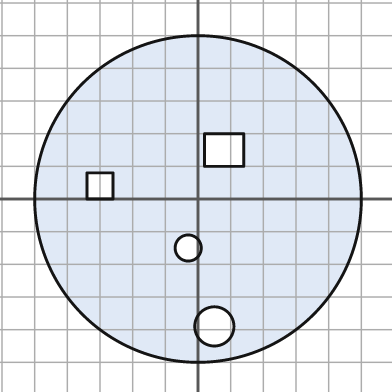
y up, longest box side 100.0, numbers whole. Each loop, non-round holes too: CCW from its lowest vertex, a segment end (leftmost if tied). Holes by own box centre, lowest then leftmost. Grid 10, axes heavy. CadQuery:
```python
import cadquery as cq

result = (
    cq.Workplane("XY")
    .moveTo(0.0, 0.0)
    .circle(50.0)
    .moveTo(5.0, -39.0)
    .circle(6.0)
    .moveTo(-3.0, -15.0)
    .circle(4.0)
    .moveTo(-34.0, 0.0)
    .lineTo(-26.0, 0.0)
    .lineTo(-26.0, 8.0)
    .lineTo(-34.0, 8.0)
    .close()
    .moveTo(2.0, 10.0)
    .lineTo(14.0, 10.0)
    .lineTo(14.0, 20.0)
    .lineTo(2.0, 20.0)
    .close()
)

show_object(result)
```